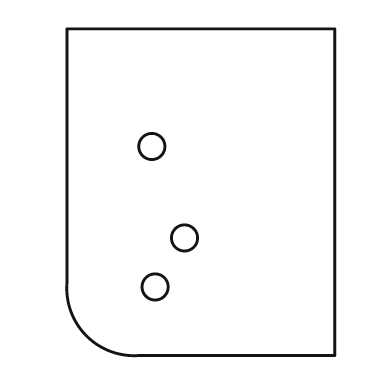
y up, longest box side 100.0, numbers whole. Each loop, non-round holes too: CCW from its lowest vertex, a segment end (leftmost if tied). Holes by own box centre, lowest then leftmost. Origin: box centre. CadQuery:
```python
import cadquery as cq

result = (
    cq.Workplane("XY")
    .moveTo(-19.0, -50.0)
    .lineTo(41.0, -50.0)
    .lineTo(41.0, 50.0)
    .lineTo(-41.0, 50.0)
    .lineTo(-41.0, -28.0)
    .threePointArc((-35.0, -44.0), (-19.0, -50.0))
    .close()
    .moveTo(-14.0, -29.0)
    .circle(4.0)
    .moveTo(-5.0, -14.0)
    .circle(4.0)
    .moveTo(-15.0, 14.0)
    .circle(4.0)
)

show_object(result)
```